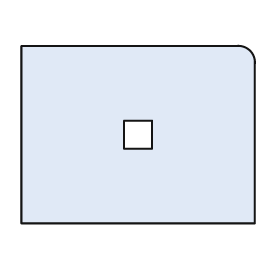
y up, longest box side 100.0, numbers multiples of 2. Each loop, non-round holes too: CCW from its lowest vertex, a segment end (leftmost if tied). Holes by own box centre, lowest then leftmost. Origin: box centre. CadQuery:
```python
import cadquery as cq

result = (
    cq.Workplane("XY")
    .moveTo(-50.0, -38.0)
    .lineTo(50.0, -38.0)
    .lineTo(50.0, 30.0)
    .threePointArc((48.0, 36.0), (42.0, 38.0))
    .lineTo(-50.0, 38.0)
    .close()
    .moveTo(-6.0, -6.0)
    .lineTo(6.0, -6.0)
    .lineTo(6.0, 6.0)
    .lineTo(-6.0, 6.0)
    .close()
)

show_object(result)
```